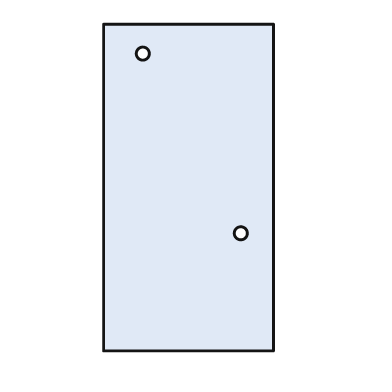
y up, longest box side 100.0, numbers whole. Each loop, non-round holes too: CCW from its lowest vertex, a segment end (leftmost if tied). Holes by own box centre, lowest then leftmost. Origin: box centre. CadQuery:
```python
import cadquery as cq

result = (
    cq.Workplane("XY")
    .moveTo(-26.0, -50.0)
    .lineTo(26.0, -50.0)
    .lineTo(26.0, 50.0)
    .lineTo(-26.0, 50.0)
    .close()
    .moveTo(16.0, -14.0)
    .circle(2.0)
    .moveTo(-14.0, 41.0)
    .circle(2.0)
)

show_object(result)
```